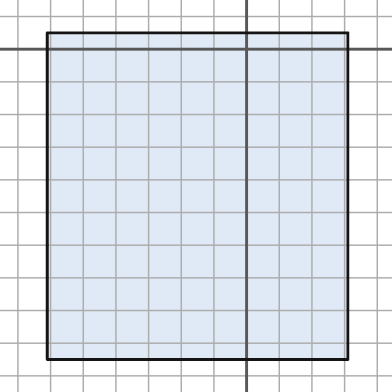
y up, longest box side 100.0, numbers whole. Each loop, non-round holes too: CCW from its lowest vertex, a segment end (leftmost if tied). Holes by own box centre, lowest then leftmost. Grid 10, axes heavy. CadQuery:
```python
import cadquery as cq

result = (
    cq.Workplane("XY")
    .moveTo(-61.0, -95.0)
    .lineTo(31.0, -95.0)
    .lineTo(31.0, 5.0)
    .lineTo(-61.0, 5.0)
    .close()
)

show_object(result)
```